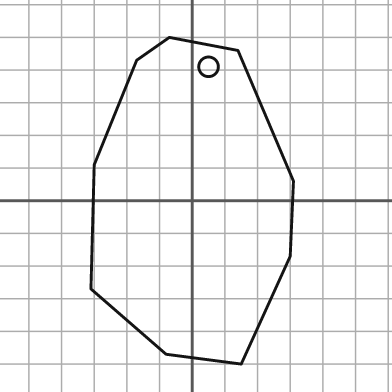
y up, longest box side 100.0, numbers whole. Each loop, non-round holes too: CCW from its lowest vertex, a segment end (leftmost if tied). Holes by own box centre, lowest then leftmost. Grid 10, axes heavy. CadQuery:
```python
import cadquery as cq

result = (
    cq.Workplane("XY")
    .moveTo(15.0, -50.0)
    .lineTo(30.0, -17.0)
    .lineTo(31.0, 6.0)
    .lineTo(14.0, 46.0)
    .lineTo(-7.0, 50.0)
    .lineTo(-17.0, 43.0)
    .lineTo(-30.0, 11.0)
    .lineTo(-31.0, -27.0)
    .lineTo(-8.0, -47.0)
    .close()
    .moveTo(5.0, 41.0)
    .circle(3.0)
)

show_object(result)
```